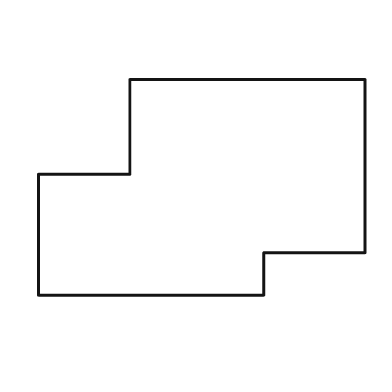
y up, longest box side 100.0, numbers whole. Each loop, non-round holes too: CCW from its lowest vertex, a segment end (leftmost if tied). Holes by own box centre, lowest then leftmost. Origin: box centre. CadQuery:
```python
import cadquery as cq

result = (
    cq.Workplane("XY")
    .moveTo(-50.0, -33.0)
    .lineTo(19.0, -33.0)
    .lineTo(19.0, -20.0)
    .lineTo(50.0, -20.0)
    .lineTo(50.0, 33.0)
    .lineTo(-22.0, 33.0)
    .lineTo(-22.0, 4.0)
    .lineTo(-50.0, 4.0)
    .close()
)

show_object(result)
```